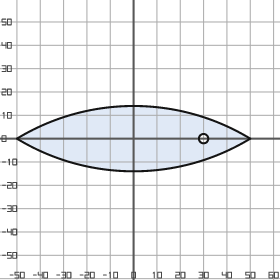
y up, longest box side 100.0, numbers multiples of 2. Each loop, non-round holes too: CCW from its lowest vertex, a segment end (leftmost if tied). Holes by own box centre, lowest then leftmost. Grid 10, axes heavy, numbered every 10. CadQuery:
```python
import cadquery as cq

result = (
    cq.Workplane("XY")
    .moveTo(-50.0, 0.0)
    .threePointArc((0.0, -14.0), (50.0, 0.0))
    .threePointArc((0.0, 14.0), (-50.0, 0.0))
    .close()
    .moveTo(30.0, 0.0)
    .circle(2.0)
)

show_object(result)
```